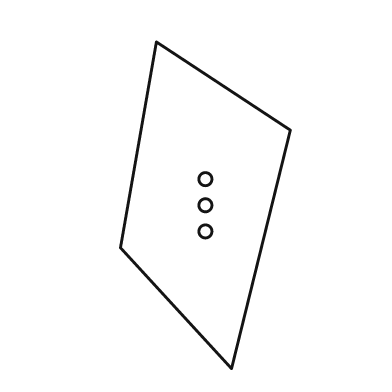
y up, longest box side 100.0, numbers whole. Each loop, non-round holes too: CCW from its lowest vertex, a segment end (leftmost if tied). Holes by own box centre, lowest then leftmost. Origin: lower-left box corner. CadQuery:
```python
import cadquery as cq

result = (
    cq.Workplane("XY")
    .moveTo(34.0, 0.0)
    .lineTo(52.0, 73.0)
    .lineTo(11.0, 100.0)
    .lineTo(0.0, 37.0)
    .close()
    .moveTo(26.0, 42.0)
    .circle(2.0)
    .moveTo(26.0, 50.0)
    .circle(2.0)
    .moveTo(26.0, 58.0)
    .circle(2.0)
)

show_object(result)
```